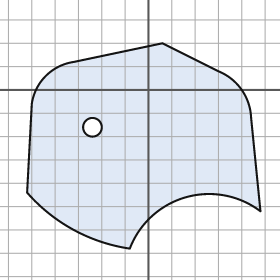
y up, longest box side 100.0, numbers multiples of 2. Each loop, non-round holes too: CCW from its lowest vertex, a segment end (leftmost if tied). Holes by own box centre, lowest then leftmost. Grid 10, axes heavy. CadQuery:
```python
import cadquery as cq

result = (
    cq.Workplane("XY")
    .moveTo(-8.0, -68.0)
    .threePointArc((16.0, -46.0), (48.0, -52.0))
    .lineTo(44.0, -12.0)
    .threePointArc((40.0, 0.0), (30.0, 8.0))
    .lineTo(6.0, 20.0)
    .lineTo(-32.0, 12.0)
    .threePointArc((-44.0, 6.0), (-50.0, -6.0))
    .lineTo(-52.0, -44.0)
    .threePointArc((-32.0, -60.0), (-8.0, -68.0))
    .close()
    .moveTo(-24.0, -16.0)
    .circle(4.0)
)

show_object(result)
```